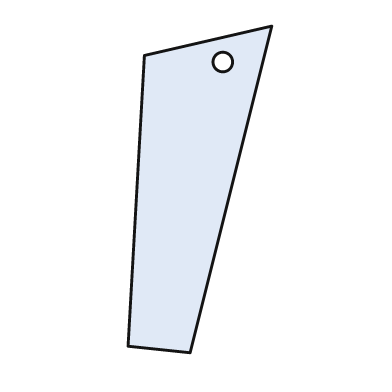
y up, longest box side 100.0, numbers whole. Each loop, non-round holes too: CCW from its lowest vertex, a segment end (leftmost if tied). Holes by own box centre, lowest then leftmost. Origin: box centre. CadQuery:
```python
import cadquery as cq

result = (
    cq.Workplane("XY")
    .moveTo(-3.0, -50.0)
    .lineTo(22.0, 50.0)
    .lineTo(-17.0, 41.0)
    .lineTo(-22.0, -48.0)
    .close()
    .moveTo(7.0, 39.0)
    .circle(3.0)
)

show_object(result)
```